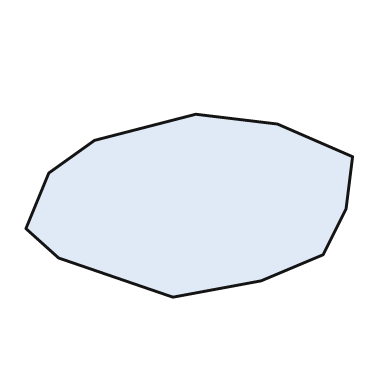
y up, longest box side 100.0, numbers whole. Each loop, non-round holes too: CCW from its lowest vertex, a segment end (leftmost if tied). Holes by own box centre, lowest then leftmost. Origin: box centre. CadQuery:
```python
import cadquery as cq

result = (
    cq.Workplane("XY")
    .moveTo(-5.0, -28.0)
    .lineTo(22.0, -23.0)
    .lineTo(41.0, -15.0)
    .lineTo(48.0, -1.0)
    .lineTo(50.0, 15.0)
    .lineTo(27.0, 25.0)
    .lineTo(2.0, 28.0)
    .lineTo(-29.0, 20.0)
    .lineTo(-43.0, 10.0)
    .lineTo(-50.0, -7.0)
    .lineTo(-40.0, -16.0)
    .close()
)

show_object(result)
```